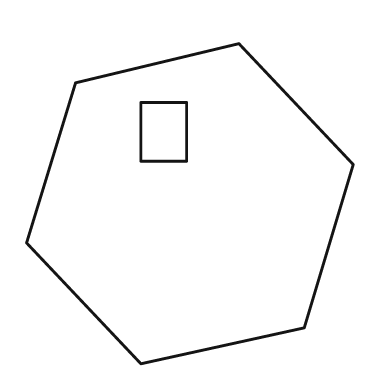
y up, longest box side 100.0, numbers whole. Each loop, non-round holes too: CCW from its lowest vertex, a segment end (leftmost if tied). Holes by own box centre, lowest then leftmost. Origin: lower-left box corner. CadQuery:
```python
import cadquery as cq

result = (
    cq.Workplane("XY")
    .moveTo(35.0, 0.0)
    .lineTo(85.0, 11.0)
    .lineTo(100.0, 61.0)
    .lineTo(65.0, 98.0)
    .lineTo(15.0, 86.0)
    .lineTo(0.0, 37.0)
    .close()
    .moveTo(35.0, 62.0)
    .lineTo(49.0, 62.0)
    .lineTo(49.0, 80.0)
    .lineTo(35.0, 80.0)
    .close()
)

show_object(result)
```